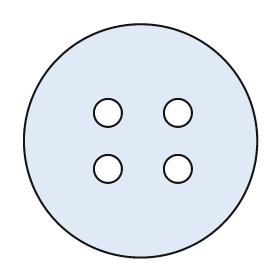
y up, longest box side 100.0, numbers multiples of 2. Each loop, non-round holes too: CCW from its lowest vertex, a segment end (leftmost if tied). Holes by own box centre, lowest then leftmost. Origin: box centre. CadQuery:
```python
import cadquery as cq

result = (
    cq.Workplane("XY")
    .moveTo(0.0, 0.0)
    .circle(50.0)
    .moveTo(-14.0, -12.0)
    .circle(6.0)
    .moveTo(16.0, -12.0)
    .circle(6.0)
    .moveTo(-14.0, 12.0)
    .circle(6.0)
    .moveTo(16.0, 12.0)
    .circle(6.0)
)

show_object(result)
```